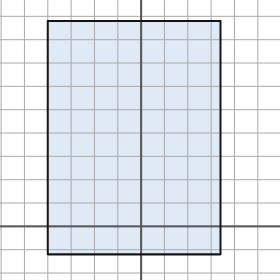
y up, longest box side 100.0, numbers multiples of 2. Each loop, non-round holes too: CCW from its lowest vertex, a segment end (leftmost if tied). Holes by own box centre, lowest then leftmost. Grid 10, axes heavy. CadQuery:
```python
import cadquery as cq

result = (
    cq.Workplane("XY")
    .moveTo(-40.0, -12.0)
    .lineTo(34.0, -12.0)
    .lineTo(34.0, 88.0)
    .lineTo(-40.0, 88.0)
    .close()
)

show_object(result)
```